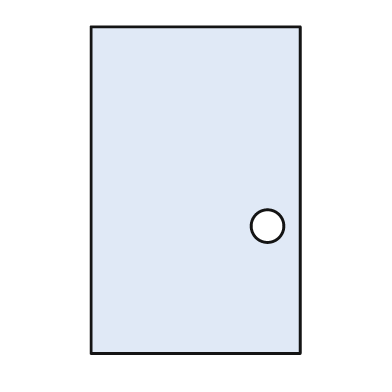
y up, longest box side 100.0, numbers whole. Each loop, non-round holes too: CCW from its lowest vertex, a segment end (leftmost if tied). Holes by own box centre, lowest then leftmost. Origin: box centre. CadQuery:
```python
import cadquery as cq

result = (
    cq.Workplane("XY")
    .moveTo(-32.0, -50.0)
    .lineTo(32.0, -50.0)
    .lineTo(32.0, 50.0)
    .lineTo(-32.0, 50.0)
    .close()
    .moveTo(22.0, -11.0)
    .circle(5.0)
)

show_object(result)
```